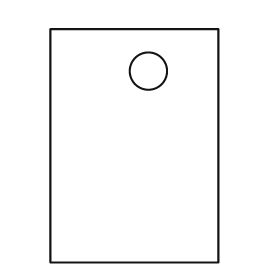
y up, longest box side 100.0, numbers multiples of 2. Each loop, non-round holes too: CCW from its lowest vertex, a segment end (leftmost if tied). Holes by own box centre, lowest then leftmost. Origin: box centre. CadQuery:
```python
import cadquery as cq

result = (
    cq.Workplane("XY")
    .moveTo(-36.0, -50.0)
    .lineTo(36.0, -50.0)
    .lineTo(36.0, 50.0)
    .lineTo(-36.0, 50.0)
    .close()
    .moveTo(6.0, 32.0)
    .circle(8.0)
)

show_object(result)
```